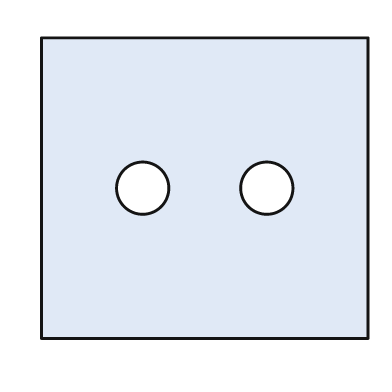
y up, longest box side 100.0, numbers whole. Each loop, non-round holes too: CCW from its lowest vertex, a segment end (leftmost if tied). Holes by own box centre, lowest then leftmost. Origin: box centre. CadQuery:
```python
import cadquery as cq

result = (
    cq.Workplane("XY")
    .moveTo(-50.0, -46.0)
    .lineTo(50.0, -46.0)
    .lineTo(50.0, 46.0)
    .lineTo(-50.0, 46.0)
    .close()
    .moveTo(-19.0, 0.0)
    .circle(8.0)
    .moveTo(19.0, 0.0)
    .circle(8.0)
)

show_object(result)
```